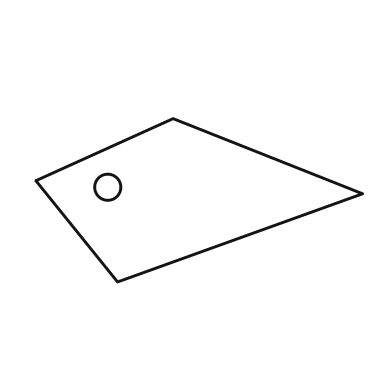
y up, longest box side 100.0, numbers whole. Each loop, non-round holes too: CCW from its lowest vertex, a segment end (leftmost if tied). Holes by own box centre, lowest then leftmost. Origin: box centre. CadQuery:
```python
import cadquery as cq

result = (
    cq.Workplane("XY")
    .moveTo(-25.0, -25.0)
    .lineTo(50.0, 2.0)
    .lineTo(-8.0, 25.0)
    .lineTo(-50.0, 6.0)
    .close()
    .moveTo(-28.0, 4.0)
    .circle(4.0)
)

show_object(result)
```